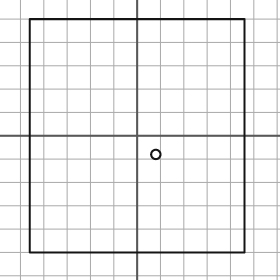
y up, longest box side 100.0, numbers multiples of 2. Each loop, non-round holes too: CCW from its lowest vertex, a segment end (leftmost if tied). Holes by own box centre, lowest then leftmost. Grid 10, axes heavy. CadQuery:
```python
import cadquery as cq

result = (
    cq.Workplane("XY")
    .moveTo(-46.0, -50.0)
    .lineTo(46.0, -50.0)
    .lineTo(46.0, 50.0)
    .lineTo(-46.0, 50.0)
    .close()
    .moveTo(8.0, -8.0)
    .circle(2.0)
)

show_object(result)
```